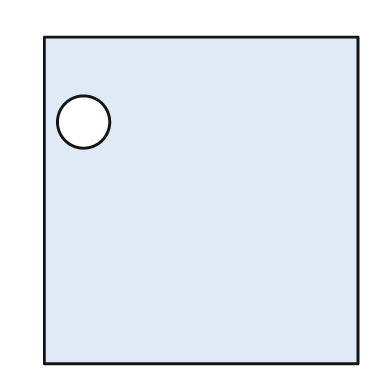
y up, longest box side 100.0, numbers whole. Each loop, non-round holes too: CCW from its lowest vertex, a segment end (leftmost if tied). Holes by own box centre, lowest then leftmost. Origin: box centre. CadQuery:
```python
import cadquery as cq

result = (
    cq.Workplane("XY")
    .moveTo(-48.0, -50.0)
    .lineTo(48.0, -50.0)
    .lineTo(48.0, 50.0)
    .lineTo(-48.0, 50.0)
    .close()
    .moveTo(-36.0, 24.0)
    .circle(8.0)
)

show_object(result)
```